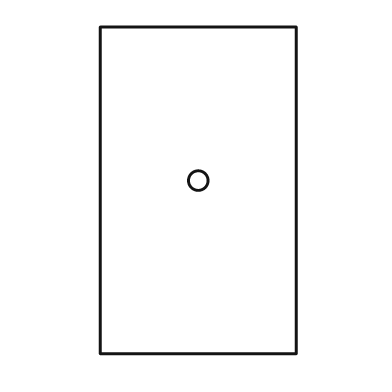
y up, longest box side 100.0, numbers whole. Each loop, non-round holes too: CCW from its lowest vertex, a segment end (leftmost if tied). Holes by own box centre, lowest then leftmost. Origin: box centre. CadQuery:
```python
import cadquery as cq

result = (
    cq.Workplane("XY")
    .moveTo(-30.0, -50.0)
    .lineTo(30.0, -50.0)
    .lineTo(30.0, 50.0)
    .lineTo(-30.0, 50.0)
    .close()
    .moveTo(0.0, 3.0)
    .circle(3.0)
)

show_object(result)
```